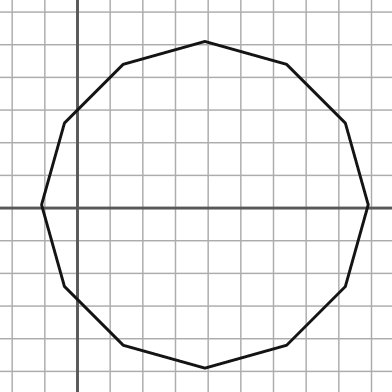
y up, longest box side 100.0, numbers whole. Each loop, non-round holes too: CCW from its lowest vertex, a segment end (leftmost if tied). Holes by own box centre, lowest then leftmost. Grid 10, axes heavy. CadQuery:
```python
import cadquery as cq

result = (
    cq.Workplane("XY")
    .moveTo(39.0, -49.0)
    .lineTo(64.0, -42.0)
    .lineTo(82.0, -24.0)
    .lineTo(89.0, 1.0)
    .lineTo(82.0, 26.0)
    .lineTo(64.0, 44.0)
    .lineTo(39.0, 51.0)
    .lineTo(14.0, 44.0)
    .lineTo(-4.0, 26.0)
    .lineTo(-11.0, 1.0)
    .lineTo(-4.0, -24.0)
    .lineTo(14.0, -42.0)
    .close()
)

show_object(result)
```